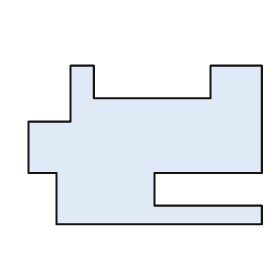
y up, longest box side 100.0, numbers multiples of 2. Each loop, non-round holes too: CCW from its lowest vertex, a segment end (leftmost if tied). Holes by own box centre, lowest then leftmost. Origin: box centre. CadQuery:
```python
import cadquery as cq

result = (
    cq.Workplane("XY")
    .moveTo(-38.0, -34.0)
    .lineTo(50.0, -34.0)
    .lineTo(50.0, -26.0)
    .lineTo(4.0, -26.0)
    .lineTo(4.0, -12.0)
    .lineTo(50.0, -12.0)
    .lineTo(50.0, 34.0)
    .lineTo(28.0, 34.0)
    .lineTo(28.0, 20.0)
    .lineTo(-22.0, 20.0)
    .lineTo(-22.0, 34.0)
    .lineTo(-32.0, 34.0)
    .lineTo(-32.0, 10.0)
    .lineTo(-50.0, 10.0)
    .lineTo(-50.0, -12.0)
    .lineTo(-38.0, -12.0)
    .close()
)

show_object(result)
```